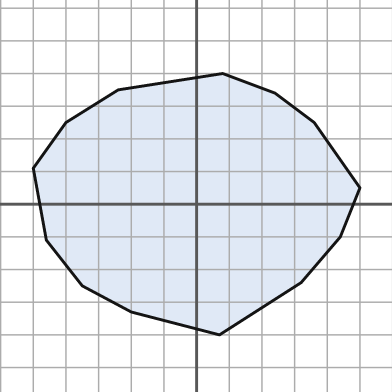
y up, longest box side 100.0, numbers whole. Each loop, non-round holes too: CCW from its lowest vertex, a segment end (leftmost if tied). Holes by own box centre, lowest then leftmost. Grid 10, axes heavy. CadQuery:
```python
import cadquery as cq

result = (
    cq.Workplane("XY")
    .moveTo(7.0, -40.0)
    .lineTo(32.0, -24.0)
    .lineTo(44.0, -10.0)
    .lineTo(50.0, 5.0)
    .lineTo(36.0, 25.0)
    .lineTo(24.0, 34.0)
    .lineTo(8.0, 40.0)
    .lineTo(-24.0, 35.0)
    .lineTo(-40.0, 25.0)
    .lineTo(-50.0, 11.0)
    .lineTo(-46.0, -11.0)
    .lineTo(-35.0, -25.0)
    .lineTo(-20.0, -33.0)
    .close()
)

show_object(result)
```